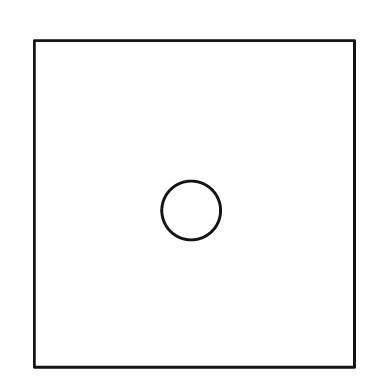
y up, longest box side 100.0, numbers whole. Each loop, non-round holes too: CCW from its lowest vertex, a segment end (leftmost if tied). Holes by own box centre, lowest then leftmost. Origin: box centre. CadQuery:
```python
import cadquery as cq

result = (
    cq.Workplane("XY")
    .moveTo(-49.0, -50.0)
    .lineTo(49.0, -50.0)
    .lineTo(49.0, 50.0)
    .lineTo(-49.0, 50.0)
    .close()
    .moveTo(-1.0, -2.0)
    .circle(9.0)
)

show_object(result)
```